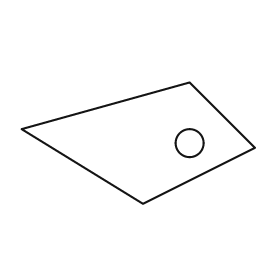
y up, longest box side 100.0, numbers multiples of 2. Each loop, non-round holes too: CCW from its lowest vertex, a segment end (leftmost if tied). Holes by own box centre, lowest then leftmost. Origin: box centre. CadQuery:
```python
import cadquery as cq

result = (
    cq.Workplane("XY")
    .moveTo(2.0, -26.0)
    .lineTo(50.0, -2.0)
    .lineTo(22.0, 26.0)
    .lineTo(-50.0, 6.0)
    .close()
    .moveTo(22.0, 0.0)
    .circle(6.0)
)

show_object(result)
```